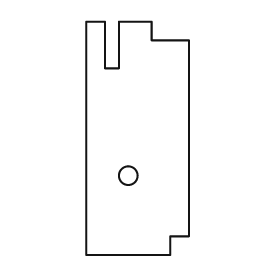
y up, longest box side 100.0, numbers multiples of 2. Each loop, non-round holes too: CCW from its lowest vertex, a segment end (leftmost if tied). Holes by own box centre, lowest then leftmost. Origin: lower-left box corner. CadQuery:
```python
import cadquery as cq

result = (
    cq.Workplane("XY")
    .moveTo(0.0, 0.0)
    .lineTo(36.0, 0.0)
    .lineTo(36.0, 8.0)
    .lineTo(44.0, 8.0)
    .lineTo(44.0, 92.0)
    .lineTo(28.0, 92.0)
    .lineTo(28.0, 100.0)
    .lineTo(14.0, 100.0)
    .lineTo(14.0, 80.0)
    .lineTo(8.0, 80.0)
    .lineTo(8.0, 100.0)
    .lineTo(0.0, 100.0)
    .close()
    .moveTo(18.0, 34.0)
    .circle(4.0)
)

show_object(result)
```